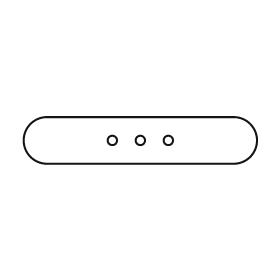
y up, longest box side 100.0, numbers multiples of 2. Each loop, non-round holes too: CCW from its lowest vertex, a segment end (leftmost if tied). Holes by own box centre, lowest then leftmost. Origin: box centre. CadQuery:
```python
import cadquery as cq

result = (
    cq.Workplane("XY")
    .moveTo(-40.0, -10.0)
    .lineTo(40.0, -10.0)
    .threePointArc((50.0, 0.0), (40.0, 10.0))
    .lineTo(-40.0, 10.0)
    .threePointArc((-50.0, 0.0), (-40.0, -10.0))
    .close()
    .moveTo(-12.0, 0.0)
    .circle(2.0)
    .moveTo(0.0, 0.0)
    .circle(2.0)
    .moveTo(12.0, 0.0)
    .circle(2.0)
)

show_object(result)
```